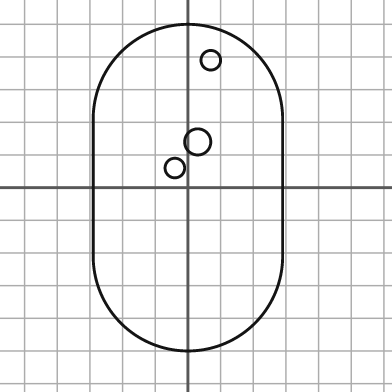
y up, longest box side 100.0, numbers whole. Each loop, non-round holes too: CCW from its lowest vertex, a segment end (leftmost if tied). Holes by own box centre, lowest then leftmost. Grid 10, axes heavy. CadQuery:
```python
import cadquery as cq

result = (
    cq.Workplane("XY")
    .moveTo(-29.0, -21.0)
    .threePointArc((0.0, -50.0), (29.0, -21.0))
    .lineTo(29.0, 21.0)
    .threePointArc((0.0, 50.0), (-29.0, 21.0))
    .close()
    .moveTo(-4.0, 6.0)
    .circle(3.0)
    .moveTo(3.0, 14.0)
    .circle(4.0)
    .moveTo(7.0, 39.0)
    .circle(3.0)
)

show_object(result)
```